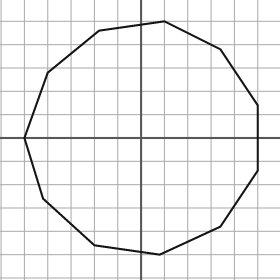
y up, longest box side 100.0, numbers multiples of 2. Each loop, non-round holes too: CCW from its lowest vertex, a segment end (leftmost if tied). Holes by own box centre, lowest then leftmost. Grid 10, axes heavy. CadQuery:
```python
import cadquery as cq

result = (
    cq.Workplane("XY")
    .moveTo(8.0, -50.0)
    .lineTo(34.0, -38.0)
    .lineTo(50.0, -14.0)
    .lineTo(50.0, 14.0)
    .lineTo(34.0, 38.0)
    .lineTo(10.0, 50.0)
    .lineTo(-18.0, 46.0)
    .lineTo(-40.0, 28.0)
    .lineTo(-50.0, 0.0)
    .lineTo(-42.0, -26.0)
    .lineTo(-20.0, -46.0)
    .close()
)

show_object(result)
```